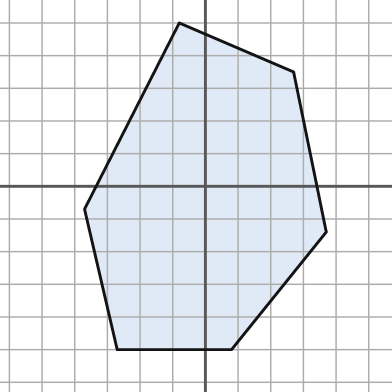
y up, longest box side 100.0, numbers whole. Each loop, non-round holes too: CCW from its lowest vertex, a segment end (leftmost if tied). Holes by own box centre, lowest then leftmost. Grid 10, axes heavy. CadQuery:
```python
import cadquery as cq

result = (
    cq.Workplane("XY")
    .moveTo(-27.0, -50.0)
    .lineTo(8.0, -50.0)
    .lineTo(37.0, -14.0)
    .lineTo(27.0, 35.0)
    .lineTo(-8.0, 50.0)
    .lineTo(-37.0, -7.0)
    .close()
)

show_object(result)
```